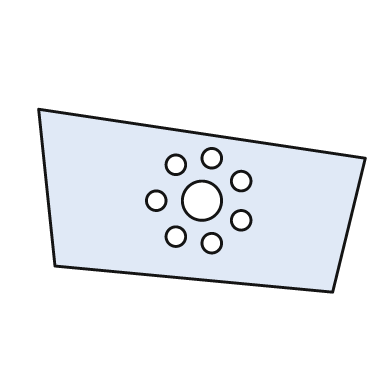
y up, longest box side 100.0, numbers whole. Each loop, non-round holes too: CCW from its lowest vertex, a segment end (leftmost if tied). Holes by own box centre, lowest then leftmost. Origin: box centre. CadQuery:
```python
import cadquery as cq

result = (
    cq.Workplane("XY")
    .moveTo(40.0, -28.0)
    .lineTo(50.0, 13.0)
    .lineTo(-50.0, 28.0)
    .lineTo(-45.0, -20.0)
    .close()
    .moveTo(3.0, -13.0)
    .circle(3.0)
    .moveTo(-8.0, -11.0)
    .circle(3.0)
    .moveTo(12.0, -6.0)
    .circle(3.0)
    .moveTo(-14.0, 0.0)
    .circle(3.0)
    .moveTo(0.0, 0.0)
    .circle(6.0)
    .moveTo(12.0, 6.0)
    .circle(3.0)
    .moveTo(-8.0, 11.0)
    .circle(3.0)
    .moveTo(3.0, 13.0)
    .circle(3.0)
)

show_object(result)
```